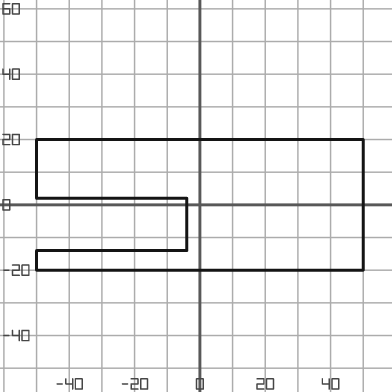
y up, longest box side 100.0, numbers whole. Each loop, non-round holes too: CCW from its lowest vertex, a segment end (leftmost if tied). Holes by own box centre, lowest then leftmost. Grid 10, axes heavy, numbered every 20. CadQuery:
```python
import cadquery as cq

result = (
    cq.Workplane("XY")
    .moveTo(-50.0, -20.0)
    .lineTo(50.0, -20.0)
    .lineTo(50.0, 20.0)
    .lineTo(-50.0, 20.0)
    .lineTo(-50.0, 2.0)
    .lineTo(-4.0, 2.0)
    .lineTo(-4.0, -14.0)
    .lineTo(-50.0, -14.0)
    .close()
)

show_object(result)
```